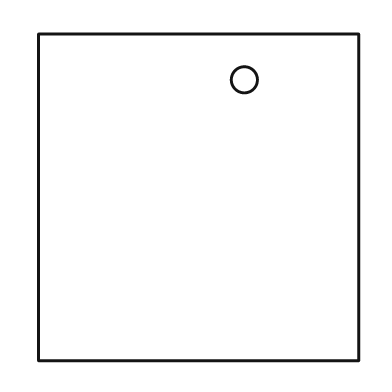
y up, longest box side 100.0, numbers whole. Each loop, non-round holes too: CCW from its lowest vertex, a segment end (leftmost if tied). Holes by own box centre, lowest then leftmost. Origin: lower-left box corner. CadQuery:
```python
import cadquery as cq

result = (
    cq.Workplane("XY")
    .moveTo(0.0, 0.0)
    .lineTo(98.0, 0.0)
    .lineTo(98.0, 100.0)
    .lineTo(0.0, 100.0)
    .close()
    .moveTo(63.0, 86.0)
    .circle(4.0)
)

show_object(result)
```